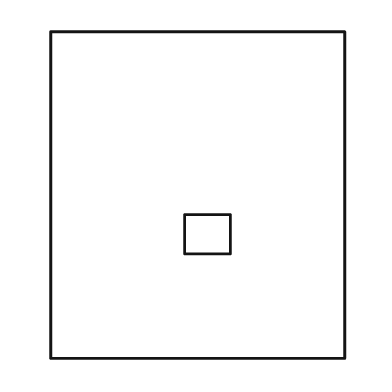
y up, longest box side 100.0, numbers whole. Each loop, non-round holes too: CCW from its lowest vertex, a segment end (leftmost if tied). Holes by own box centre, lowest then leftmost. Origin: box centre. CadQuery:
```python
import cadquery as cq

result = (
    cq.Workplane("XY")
    .moveTo(-45.0, -50.0)
    .lineTo(45.0, -50.0)
    .lineTo(45.0, 50.0)
    .lineTo(-45.0, 50.0)
    .close()
    .moveTo(-4.0, -18.0)
    .lineTo(10.0, -18.0)
    .lineTo(10.0, -6.0)
    .lineTo(-4.0, -6.0)
    .close()
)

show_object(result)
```